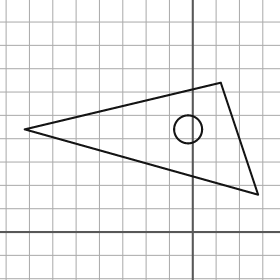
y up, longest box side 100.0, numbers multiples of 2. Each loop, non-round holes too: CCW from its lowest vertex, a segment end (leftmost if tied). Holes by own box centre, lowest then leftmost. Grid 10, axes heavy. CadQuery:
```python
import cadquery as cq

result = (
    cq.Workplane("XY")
    .moveTo(28.0, 16.0)
    .lineTo(12.0, 64.0)
    .lineTo(-72.0, 44.0)
    .close()
    .moveTo(-2.0, 44.0)
    .circle(6.0)
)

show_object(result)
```